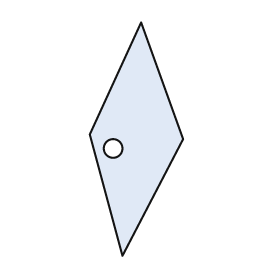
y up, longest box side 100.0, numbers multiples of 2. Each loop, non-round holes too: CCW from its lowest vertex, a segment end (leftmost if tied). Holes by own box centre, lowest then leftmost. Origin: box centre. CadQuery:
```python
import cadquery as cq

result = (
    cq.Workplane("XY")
    .moveTo(-6.0, -50.0)
    .lineTo(20.0, 0.0)
    .lineTo(2.0, 50.0)
    .lineTo(-20.0, 2.0)
    .close()
    .moveTo(-10.0, -4.0)
    .circle(4.0)
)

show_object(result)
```